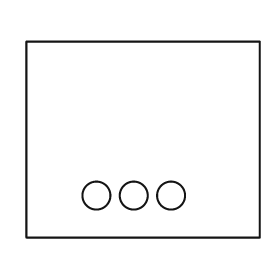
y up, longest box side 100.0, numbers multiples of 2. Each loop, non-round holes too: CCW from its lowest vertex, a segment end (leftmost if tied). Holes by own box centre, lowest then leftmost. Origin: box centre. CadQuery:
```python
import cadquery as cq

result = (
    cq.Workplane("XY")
    .moveTo(-50.0, -42.0)
    .lineTo(50.0, -42.0)
    .lineTo(50.0, 42.0)
    .lineTo(-50.0, 42.0)
    .close()
    .moveTo(-20.0, -24.0)
    .circle(6.0)
    .moveTo(-4.0, -24.0)
    .circle(6.0)
    .moveTo(12.0, -24.0)
    .circle(6.0)
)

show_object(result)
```